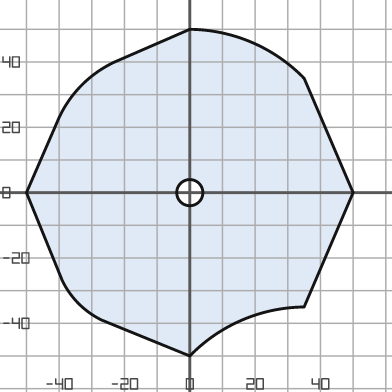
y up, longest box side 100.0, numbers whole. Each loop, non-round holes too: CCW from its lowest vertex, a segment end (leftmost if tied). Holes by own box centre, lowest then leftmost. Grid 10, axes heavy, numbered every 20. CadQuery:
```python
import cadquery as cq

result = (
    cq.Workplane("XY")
    .moveTo(0.0, -50.0)
    .threePointArc((16.0, -39.0), (35.0, -35.0))
    .lineTo(50.0, 0.0)
    .lineTo(35.0, 35.0)
    .threePointArc((19.0, 46.0), (0.0, 50.0))
    .lineTo(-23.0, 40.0)
    .threePointArc((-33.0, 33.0), (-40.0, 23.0))
    .lineTo(-50.0, 0.0)
    .lineTo(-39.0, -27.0)
    .threePointArc((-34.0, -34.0), (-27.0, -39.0))
    .close()
    .moveTo(0.0, 0.0)
    .circle(4.0)
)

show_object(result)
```